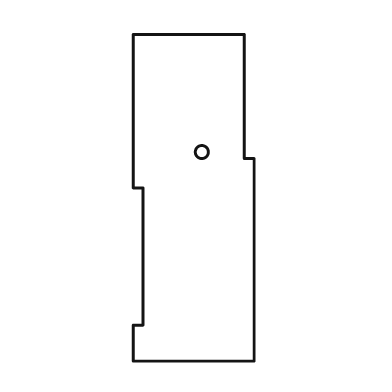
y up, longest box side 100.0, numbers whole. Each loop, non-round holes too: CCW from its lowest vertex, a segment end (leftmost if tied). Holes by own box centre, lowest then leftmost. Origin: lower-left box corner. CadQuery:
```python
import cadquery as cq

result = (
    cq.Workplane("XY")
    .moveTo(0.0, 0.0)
    .lineTo(37.0, 0.0)
    .lineTo(37.0, 62.0)
    .lineTo(34.0, 62.0)
    .lineTo(34.0, 100.0)
    .lineTo(0.0, 100.0)
    .lineTo(0.0, 53.0)
    .lineTo(3.0, 53.0)
    .lineTo(3.0, 11.0)
    .lineTo(0.0, 11.0)
    .close()
    .moveTo(21.0, 64.0)
    .circle(2.0)
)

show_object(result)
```